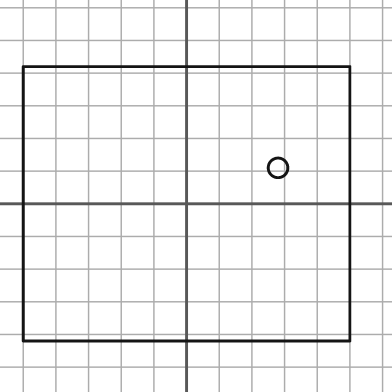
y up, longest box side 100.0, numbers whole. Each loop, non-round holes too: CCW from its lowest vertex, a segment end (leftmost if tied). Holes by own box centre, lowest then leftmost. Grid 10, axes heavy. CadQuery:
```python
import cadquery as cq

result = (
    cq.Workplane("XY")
    .moveTo(-50.0, -42.0)
    .lineTo(50.0, -42.0)
    .lineTo(50.0, 42.0)
    .lineTo(-50.0, 42.0)
    .close()
    .moveTo(28.0, 11.0)
    .circle(3.0)
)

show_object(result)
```